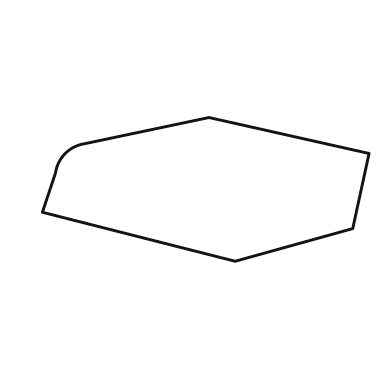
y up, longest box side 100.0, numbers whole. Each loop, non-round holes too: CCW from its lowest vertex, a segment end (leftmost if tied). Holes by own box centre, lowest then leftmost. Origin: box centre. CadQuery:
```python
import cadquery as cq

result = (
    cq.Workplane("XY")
    .moveTo(9.0, -22.0)
    .lineTo(45.0, -12.0)
    .lineTo(50.0, 11.0)
    .lineTo(1.0, 22.0)
    .lineTo(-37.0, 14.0)
    .threePointArc((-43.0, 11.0), (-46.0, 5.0))
    .lineTo(-50.0, -7.0)
    .close()
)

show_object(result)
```